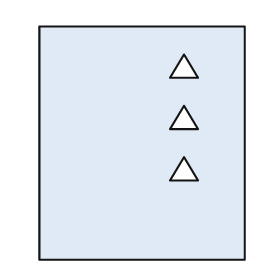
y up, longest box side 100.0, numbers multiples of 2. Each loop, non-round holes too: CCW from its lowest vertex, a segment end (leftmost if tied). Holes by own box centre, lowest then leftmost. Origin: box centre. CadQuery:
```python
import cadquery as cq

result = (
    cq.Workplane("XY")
    .moveTo(-44.0, -50.0)
    .lineTo(44.0, -50.0)
    .lineTo(44.0, 50.0)
    .lineTo(-44.0, 50.0)
    .close()
    .moveTo(12.0, -16.0)
    .lineTo(24.0, -16.0)
    .lineTo(18.0, -6.0)
    .close()
    .moveTo(12.0, 6.0)
    .lineTo(24.0, 6.0)
    .lineTo(18.0, 16.0)
    .close()
    .moveTo(12.0, 28.0)
    .lineTo(24.0, 28.0)
    .lineTo(18.0, 38.0)
    .close()
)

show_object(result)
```